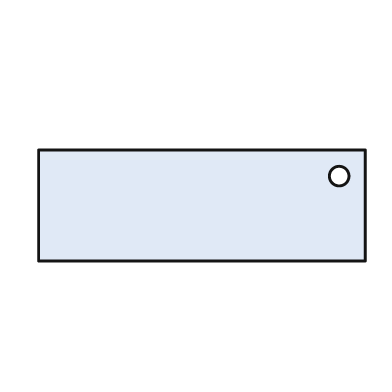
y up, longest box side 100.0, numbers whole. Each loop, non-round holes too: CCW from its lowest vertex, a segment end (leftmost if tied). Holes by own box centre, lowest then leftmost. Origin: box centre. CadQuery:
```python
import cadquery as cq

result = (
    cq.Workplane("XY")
    .moveTo(-50.0, -17.0)
    .lineTo(50.0, -17.0)
    .lineTo(50.0, 17.0)
    .lineTo(-50.0, 17.0)
    .close()
    .moveTo(42.0, 9.0)
    .circle(3.0)
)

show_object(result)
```